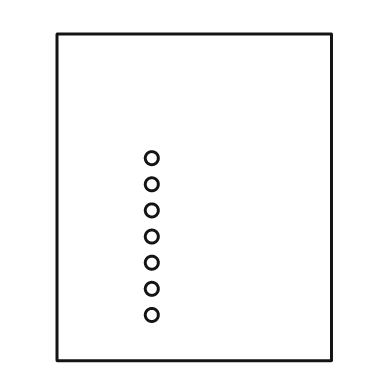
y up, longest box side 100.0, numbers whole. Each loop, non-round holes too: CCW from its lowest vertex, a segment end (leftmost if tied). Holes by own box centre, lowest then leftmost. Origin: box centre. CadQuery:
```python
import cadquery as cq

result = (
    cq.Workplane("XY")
    .moveTo(-42.0, -50.0)
    .lineTo(42.0, -50.0)
    .lineTo(42.0, 50.0)
    .lineTo(-42.0, 50.0)
    .close()
    .moveTo(-13.0, -36.0)
    .circle(2.0)
    .moveTo(-13.0, -28.0)
    .circle(2.0)
    .moveTo(-13.0, -20.0)
    .circle(2.0)
    .moveTo(-13.0, -12.0)
    .circle(2.0)
    .moveTo(-13.0, -4.0)
    .circle(2.0)
    .moveTo(-13.0, 4.0)
    .circle(2.0)
    .moveTo(-13.0, 12.0)
    .circle(2.0)
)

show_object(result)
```